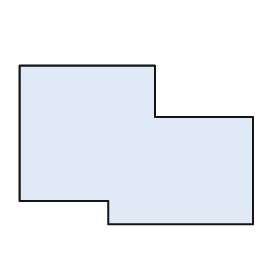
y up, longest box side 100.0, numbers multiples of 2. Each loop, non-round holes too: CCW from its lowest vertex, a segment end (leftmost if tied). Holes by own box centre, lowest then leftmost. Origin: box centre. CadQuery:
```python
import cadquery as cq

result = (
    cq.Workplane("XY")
    .moveTo(-12.0, -34.0)
    .lineTo(50.0, -34.0)
    .lineTo(50.0, 12.0)
    .lineTo(8.0, 12.0)
    .lineTo(8.0, 34.0)
    .lineTo(-50.0, 34.0)
    .lineTo(-50.0, -24.0)
    .lineTo(-12.0, -24.0)
    .close()
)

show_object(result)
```